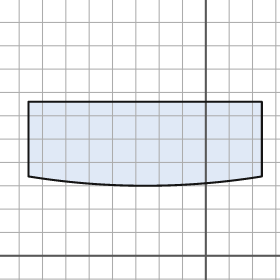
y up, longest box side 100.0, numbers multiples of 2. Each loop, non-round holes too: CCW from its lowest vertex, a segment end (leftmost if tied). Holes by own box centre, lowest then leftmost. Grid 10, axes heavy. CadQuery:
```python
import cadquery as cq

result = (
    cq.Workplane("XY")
    .moveTo(-76.0, 34.0)
    .threePointArc((-26.0, 30.0), (24.0, 34.0))
    .lineTo(24.0, 66.0)
    .lineTo(-76.0, 66.0)
    .close()
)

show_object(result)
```